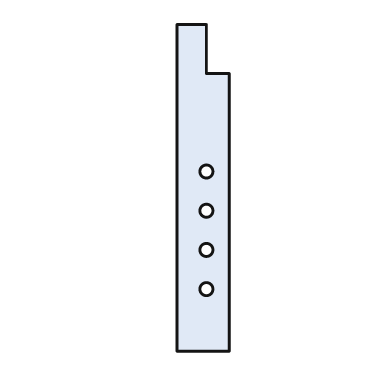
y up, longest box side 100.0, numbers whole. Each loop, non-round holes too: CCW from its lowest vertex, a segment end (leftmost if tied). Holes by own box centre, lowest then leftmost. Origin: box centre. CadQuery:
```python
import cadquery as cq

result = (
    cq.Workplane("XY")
    .moveTo(-8.0, -50.0)
    .lineTo(8.0, -50.0)
    .lineTo(8.0, 35.0)
    .lineTo(1.0, 35.0)
    .lineTo(1.0, 50.0)
    .lineTo(-8.0, 50.0)
    .close()
    .moveTo(1.0, -31.0)
    .circle(2.0)
    .moveTo(1.0, -19.0)
    .circle(2.0)
    .moveTo(1.0, -7.0)
    .circle(2.0)
    .moveTo(1.0, 5.0)
    .circle(2.0)
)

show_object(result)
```